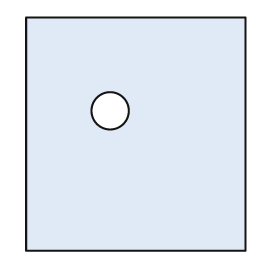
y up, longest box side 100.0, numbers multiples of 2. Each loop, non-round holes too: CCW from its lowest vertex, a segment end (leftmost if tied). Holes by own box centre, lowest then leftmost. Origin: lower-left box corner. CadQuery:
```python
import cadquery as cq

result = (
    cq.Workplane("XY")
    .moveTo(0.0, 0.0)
    .lineTo(94.0, 0.0)
    .lineTo(94.0, 100.0)
    .lineTo(0.0, 100.0)
    .close()
    .moveTo(36.0, 60.0)
    .circle(8.0)
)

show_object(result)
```